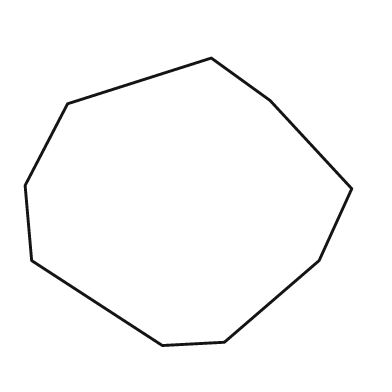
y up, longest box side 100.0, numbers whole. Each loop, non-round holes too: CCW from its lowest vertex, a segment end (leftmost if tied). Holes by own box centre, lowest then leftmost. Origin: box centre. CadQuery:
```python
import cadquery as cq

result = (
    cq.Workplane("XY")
    .moveTo(-8.0, -44.0)
    .lineTo(11.0, -43.0)
    .lineTo(40.0, -18.0)
    .lineTo(50.0, 4.0)
    .lineTo(25.0, 31.0)
    .lineTo(7.0, 44.0)
    .lineTo(-37.0, 30.0)
    .lineTo(-50.0, 5.0)
    .lineTo(-48.0, -18.0)
    .close()
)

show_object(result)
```